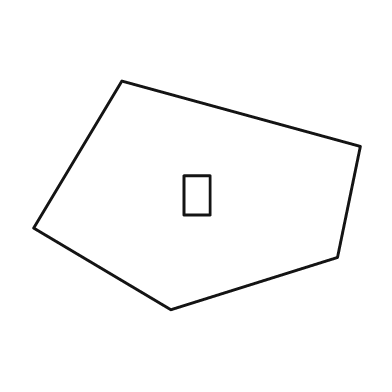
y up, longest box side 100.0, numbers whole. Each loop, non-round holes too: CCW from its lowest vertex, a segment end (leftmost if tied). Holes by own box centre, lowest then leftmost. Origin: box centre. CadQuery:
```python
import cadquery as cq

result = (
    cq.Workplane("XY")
    .moveTo(-8.0, -35.0)
    .lineTo(43.0, -19.0)
    .lineTo(50.0, 15.0)
    .lineTo(-23.0, 35.0)
    .lineTo(-50.0, -10.0)
    .close()
    .moveTo(-4.0, -6.0)
    .lineTo(4.0, -6.0)
    .lineTo(4.0, 6.0)
    .lineTo(-4.0, 6.0)
    .close()
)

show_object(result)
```